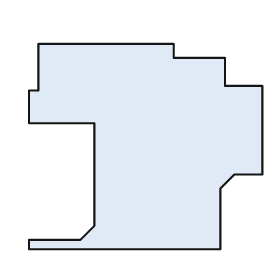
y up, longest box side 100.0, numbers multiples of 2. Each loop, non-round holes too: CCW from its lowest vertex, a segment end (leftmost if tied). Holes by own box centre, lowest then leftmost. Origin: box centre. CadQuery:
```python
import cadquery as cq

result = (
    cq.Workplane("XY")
    .moveTo(-50.0, -44.0)
    .lineTo(32.0, -44.0)
    .lineTo(32.0, -18.0)
    .lineTo(38.0, -12.0)
    .lineTo(50.0, -12.0)
    .lineTo(50.0, 26.0)
    .lineTo(34.0, 26.0)
    .lineTo(34.0, 38.0)
    .lineTo(12.0, 38.0)
    .lineTo(12.0, 44.0)
    .lineTo(-46.0, 44.0)
    .lineTo(-46.0, 24.0)
    .lineTo(-50.0, 24.0)
    .lineTo(-50.0, 10.0)
    .lineTo(-22.0, 10.0)
    .lineTo(-22.0, -34.0)
    .lineTo(-28.0, -40.0)
    .lineTo(-50.0, -40.0)
    .close()
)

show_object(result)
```